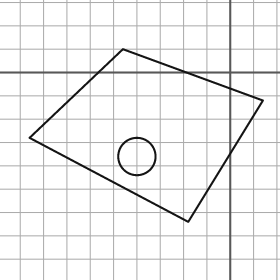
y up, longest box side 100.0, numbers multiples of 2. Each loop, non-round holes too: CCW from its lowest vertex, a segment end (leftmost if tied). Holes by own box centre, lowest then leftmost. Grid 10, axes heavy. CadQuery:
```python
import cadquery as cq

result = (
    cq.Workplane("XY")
    .moveTo(-18.0, -64.0)
    .lineTo(14.0, -12.0)
    .lineTo(-46.0, 10.0)
    .lineTo(-86.0, -28.0)
    .close()
    .moveTo(-40.0, -36.0)
    .circle(8.0)
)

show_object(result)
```